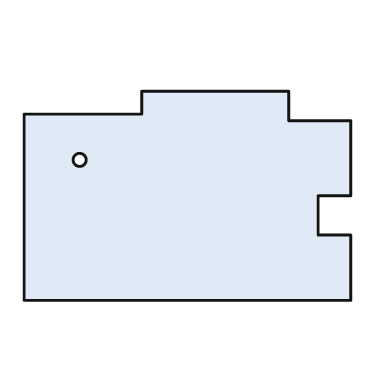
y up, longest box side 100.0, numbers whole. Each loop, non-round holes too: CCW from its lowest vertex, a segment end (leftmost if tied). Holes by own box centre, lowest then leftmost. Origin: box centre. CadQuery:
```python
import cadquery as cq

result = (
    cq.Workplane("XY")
    .moveTo(-50.0, -32.0)
    .lineTo(50.0, -32.0)
    .lineTo(50.0, -12.0)
    .lineTo(40.0, -12.0)
    .lineTo(40.0, 0.0)
    .lineTo(50.0, 0.0)
    .lineTo(50.0, 23.0)
    .lineTo(31.0, 23.0)
    .lineTo(31.0, 32.0)
    .lineTo(-14.0, 32.0)
    .lineTo(-14.0, 25.0)
    .lineTo(-50.0, 25.0)
    .close()
    .moveTo(-33.0, 11.0)
    .circle(2.0)
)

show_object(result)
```